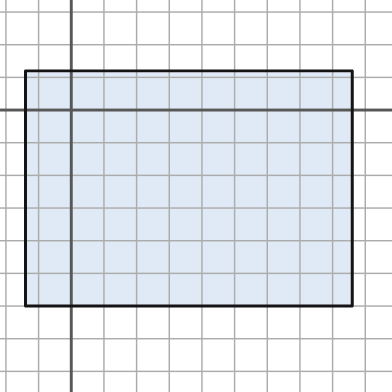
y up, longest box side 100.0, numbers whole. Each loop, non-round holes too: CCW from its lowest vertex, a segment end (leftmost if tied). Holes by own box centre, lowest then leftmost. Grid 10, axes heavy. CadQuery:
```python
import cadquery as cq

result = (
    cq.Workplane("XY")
    .moveTo(-14.0, -60.0)
    .lineTo(86.0, -60.0)
    .lineTo(86.0, 12.0)
    .lineTo(-14.0, 12.0)
    .close()
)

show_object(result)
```